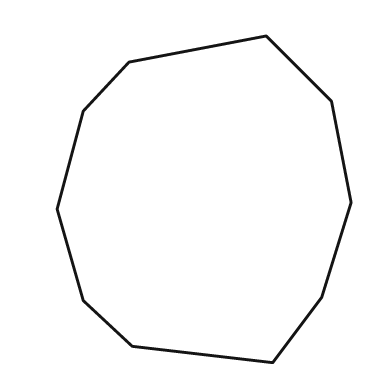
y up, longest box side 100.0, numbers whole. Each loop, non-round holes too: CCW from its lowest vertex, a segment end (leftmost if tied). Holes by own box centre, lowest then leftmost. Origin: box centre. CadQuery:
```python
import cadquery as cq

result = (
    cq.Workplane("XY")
    .moveTo(21.0, -50.0)
    .lineTo(36.0, -30.0)
    .lineTo(45.0, -1.0)
    .lineTo(39.0, 30.0)
    .lineTo(19.0, 50.0)
    .lineTo(-23.0, 42.0)
    .lineTo(-37.0, 27.0)
    .lineTo(-45.0, -3.0)
    .lineTo(-37.0, -31.0)
    .lineTo(-22.0, -45.0)
    .close()
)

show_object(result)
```